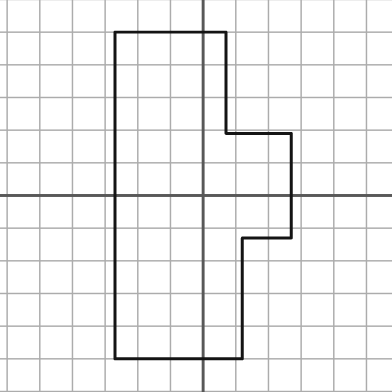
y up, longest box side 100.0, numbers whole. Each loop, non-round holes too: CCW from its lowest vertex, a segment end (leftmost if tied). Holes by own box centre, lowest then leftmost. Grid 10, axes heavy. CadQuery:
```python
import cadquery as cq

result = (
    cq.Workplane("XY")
    .moveTo(-27.0, -50.0)
    .lineTo(12.0, -50.0)
    .lineTo(12.0, -13.0)
    .lineTo(27.0, -13.0)
    .lineTo(27.0, 19.0)
    .lineTo(7.0, 19.0)
    .lineTo(7.0, 50.0)
    .lineTo(-27.0, 50.0)
    .close()
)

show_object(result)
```